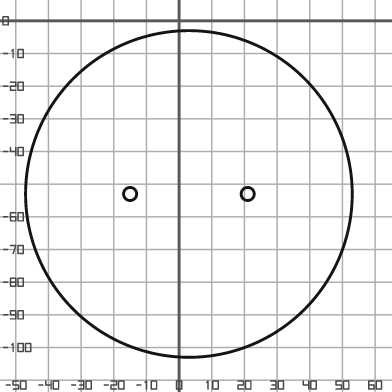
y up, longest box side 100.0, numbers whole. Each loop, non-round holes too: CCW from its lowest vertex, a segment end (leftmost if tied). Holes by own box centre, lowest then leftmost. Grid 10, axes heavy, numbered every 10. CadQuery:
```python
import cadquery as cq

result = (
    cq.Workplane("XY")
    .moveTo(3.0, -53.0)
    .circle(50.0)
    .moveTo(-15.0, -53.0)
    .circle(2.0)
    .moveTo(21.0, -53.0)
    .circle(2.0)
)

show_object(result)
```